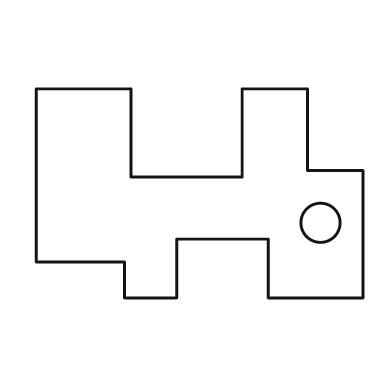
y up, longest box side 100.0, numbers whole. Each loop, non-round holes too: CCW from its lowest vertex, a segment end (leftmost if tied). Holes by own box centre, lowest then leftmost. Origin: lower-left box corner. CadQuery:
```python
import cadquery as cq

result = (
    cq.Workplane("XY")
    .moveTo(27.0, 0.0)
    .lineTo(43.0, 0.0)
    .lineTo(43.0, 18.0)
    .lineTo(71.0, 18.0)
    .lineTo(71.0, 0.0)
    .lineTo(100.0, 0.0)
    .lineTo(100.0, 39.0)
    .lineTo(83.0, 39.0)
    .lineTo(83.0, 64.0)
    .lineTo(63.0, 64.0)
    .lineTo(63.0, 37.0)
    .lineTo(29.0, 37.0)
    .lineTo(29.0, 64.0)
    .lineTo(0.0, 64.0)
    .lineTo(0.0, 11.0)
    .lineTo(27.0, 11.0)
    .close()
    .moveTo(87.0, 23.0)
    .circle(6.0)
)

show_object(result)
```